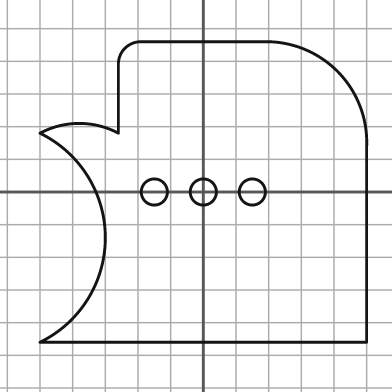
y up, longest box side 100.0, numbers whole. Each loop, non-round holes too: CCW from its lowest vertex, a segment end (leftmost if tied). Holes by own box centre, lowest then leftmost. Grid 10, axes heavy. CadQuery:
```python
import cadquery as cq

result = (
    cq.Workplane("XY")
    .moveTo(-50.0, -46.0)
    .lineTo(50.0, -46.0)
    .lineTo(50.0, 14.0)
    .threePointArc((41.0, 37.0), (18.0, 46.0))
    .lineTo(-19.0, 46.0)
    .threePointArc((-24.0, 44.0), (-26.0, 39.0))
    .lineTo(-26.0, 18.0)
    .threePointArc((-38.0, 21.0), (-50.0, 18.0))
    .threePointArc((-30.0, -14.0), (-50.0, -46.0))
    .close()
    .moveTo(-15.0, 0.0)
    .circle(4.0)
    .moveTo(0.0, 0.0)
    .circle(4.0)
    .moveTo(15.0, 0.0)
    .circle(4.0)
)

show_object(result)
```